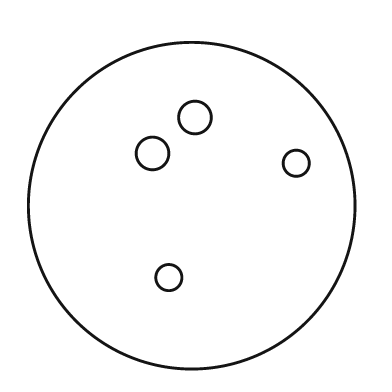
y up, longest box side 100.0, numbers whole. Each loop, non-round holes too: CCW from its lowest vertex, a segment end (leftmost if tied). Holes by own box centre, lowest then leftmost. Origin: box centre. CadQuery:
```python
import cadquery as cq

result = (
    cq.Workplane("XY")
    .moveTo(0.0, 0.0)
    .circle(50.0)
    .moveTo(-7.0, -22.0)
    .circle(4.0)
    .moveTo(32.0, 13.0)
    .circle(4.0)
    .moveTo(-12.0, 16.0)
    .circle(5.0)
    .moveTo(1.0, 27.0)
    .circle(5.0)
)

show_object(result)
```